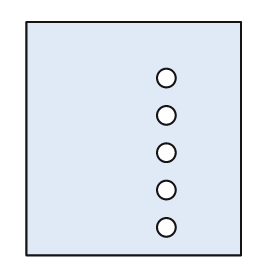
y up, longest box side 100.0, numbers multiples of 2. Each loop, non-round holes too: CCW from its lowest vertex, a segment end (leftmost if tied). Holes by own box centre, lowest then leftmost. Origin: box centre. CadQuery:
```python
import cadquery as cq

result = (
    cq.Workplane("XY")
    .moveTo(-46.0, -50.0)
    .lineTo(46.0, -50.0)
    .lineTo(46.0, 50.0)
    .lineTo(-46.0, 50.0)
    .close()
    .moveTo(14.0, -38.0)
    .circle(4.0)
    .moveTo(14.0, -22.0)
    .circle(4.0)
    .moveTo(14.0, -6.0)
    .circle(4.0)
    .moveTo(14.0, 10.0)
    .circle(4.0)
    .moveTo(14.0, 26.0)
    .circle(4.0)
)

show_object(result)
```